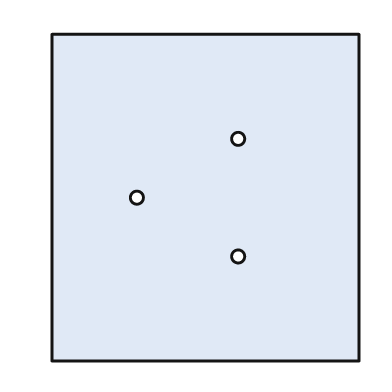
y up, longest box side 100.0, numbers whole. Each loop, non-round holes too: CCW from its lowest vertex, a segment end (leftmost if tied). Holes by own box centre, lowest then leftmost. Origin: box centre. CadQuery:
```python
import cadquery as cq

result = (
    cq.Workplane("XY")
    .moveTo(-47.0, -50.0)
    .lineTo(47.0, -50.0)
    .lineTo(47.0, 50.0)
    .lineTo(-47.0, 50.0)
    .close()
    .moveTo(10.0, -18.0)
    .circle(2.0)
    .moveTo(-21.0, 0.0)
    .circle(2.0)
    .moveTo(10.0, 18.0)
    .circle(2.0)
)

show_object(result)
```